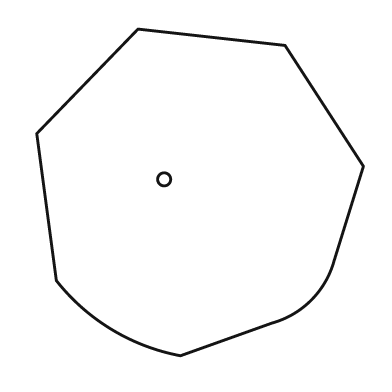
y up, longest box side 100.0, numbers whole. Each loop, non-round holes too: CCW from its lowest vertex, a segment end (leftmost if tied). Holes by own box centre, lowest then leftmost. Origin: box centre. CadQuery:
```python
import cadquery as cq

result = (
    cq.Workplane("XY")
    .moveTo(-6.0, -50.0)
    .lineTo(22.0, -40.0)
    .threePointArc((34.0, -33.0), (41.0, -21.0))
    .lineTo(50.0, 8.0)
    .lineTo(26.0, 45.0)
    .lineTo(-19.0, 50.0)
    .lineTo(-50.0, 18.0)
    .lineTo(-44.0, -27.0)
    .threePointArc((-27.0, -42.0), (-6.0, -50.0))
    .close()
    .moveTo(-11.0, 4.0)
    .circle(2.0)
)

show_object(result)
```